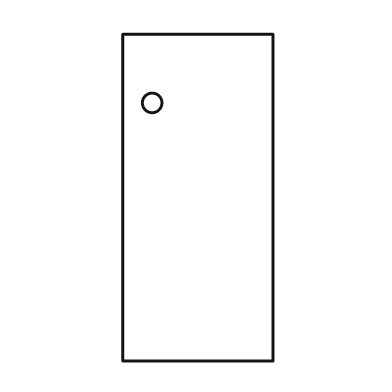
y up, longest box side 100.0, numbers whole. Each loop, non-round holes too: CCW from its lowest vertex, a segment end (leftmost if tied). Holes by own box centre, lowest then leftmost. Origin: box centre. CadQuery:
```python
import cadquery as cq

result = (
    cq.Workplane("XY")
    .moveTo(-23.0, -50.0)
    .lineTo(23.0, -50.0)
    .lineTo(23.0, 50.0)
    .lineTo(-23.0, 50.0)
    .close()
    .moveTo(-14.0, 29.0)
    .circle(3.0)
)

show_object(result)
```